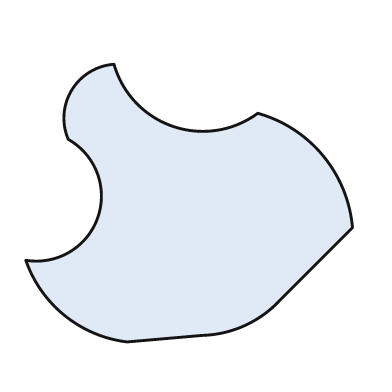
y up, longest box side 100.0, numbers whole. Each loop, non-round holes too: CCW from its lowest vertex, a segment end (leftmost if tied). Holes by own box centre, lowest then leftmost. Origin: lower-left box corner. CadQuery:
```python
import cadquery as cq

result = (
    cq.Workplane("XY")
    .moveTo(31.0, 0.0)
    .lineTo(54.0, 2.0)
    .threePointArc((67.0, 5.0), (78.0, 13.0))
    .lineTo(100.0, 35.0)
    .threePointArc((91.0, 57.0), (71.0, 70.0))
    .threePointArc((45.0, 66.0), (27.0, 85.0))
    .threePointArc((14.0, 77.0), (13.0, 62.0))
    .threePointArc((22.0, 38.0), (0.0, 25.0))
    .threePointArc((12.0, 8.0), (31.0, 0.0))
    .close()
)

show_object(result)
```